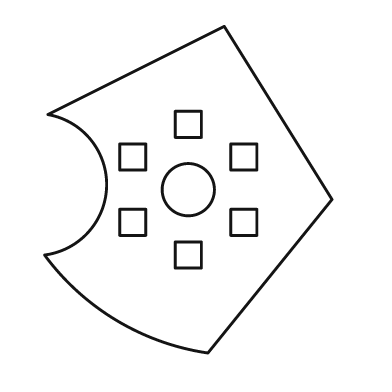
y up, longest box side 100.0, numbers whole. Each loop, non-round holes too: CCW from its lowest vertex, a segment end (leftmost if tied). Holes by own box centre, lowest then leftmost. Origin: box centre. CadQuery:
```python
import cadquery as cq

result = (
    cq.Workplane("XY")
    .moveTo(6.0, -50.0)
    .lineTo(44.0, -3.0)
    .lineTo(11.0, 50.0)
    .lineTo(-43.0, 23.0)
    .threePointArc((-25.0, 1.0), (-44.0, -20.0))
    .threePointArc((-22.0, -40.0), (6.0, -50.0))
    .close()
    .moveTo(-4.0, -24.0)
    .lineTo(4.0, -24.0)
    .lineTo(4.0, -16.0)
    .lineTo(-4.0, -16.0)
    .close()
    .moveTo(-21.0, -14.0)
    .lineTo(-13.0, -14.0)
    .lineTo(-13.0, -6.0)
    .lineTo(-21.0, -6.0)
    .close()
    .moveTo(13.0, -14.0)
    .lineTo(21.0, -14.0)
    .lineTo(21.0, -6.0)
    .lineTo(13.0, -6.0)
    .close()
    .moveTo(0.0, 0.0)
    .circle(8.0)
    .moveTo(-21.0, 6.0)
    .lineTo(-13.0, 6.0)
    .lineTo(-13.0, 14.0)
    .lineTo(-21.0, 14.0)
    .close()
    .moveTo(13.0, 6.0)
    .lineTo(21.0, 6.0)
    .lineTo(21.0, 14.0)
    .lineTo(13.0, 14.0)
    .close()
    .moveTo(-4.0, 16.0)
    .lineTo(4.0, 16.0)
    .lineTo(4.0, 24.0)
    .lineTo(-4.0, 24.0)
    .close()
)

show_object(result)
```